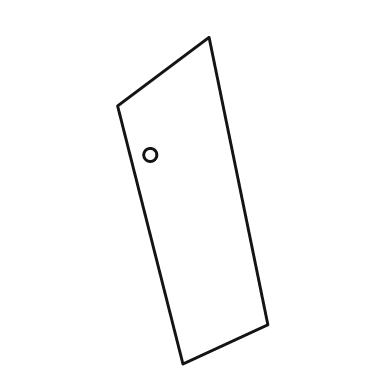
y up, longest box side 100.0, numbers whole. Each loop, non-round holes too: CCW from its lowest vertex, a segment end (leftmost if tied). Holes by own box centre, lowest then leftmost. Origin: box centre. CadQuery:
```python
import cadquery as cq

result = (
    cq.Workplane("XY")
    .moveTo(-3.0, -50.0)
    .lineTo(23.0, -38.0)
    .lineTo(5.0, 50.0)
    .lineTo(-23.0, 29.0)
    .close()
    .moveTo(-13.0, 14.0)
    .circle(2.0)
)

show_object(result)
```